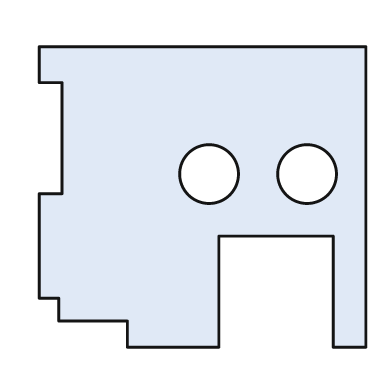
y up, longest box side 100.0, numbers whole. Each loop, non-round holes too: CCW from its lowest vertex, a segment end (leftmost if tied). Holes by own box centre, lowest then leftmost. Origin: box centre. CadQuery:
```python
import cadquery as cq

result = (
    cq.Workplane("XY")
    .moveTo(-23.0, -46.0)
    .lineTo(5.0, -46.0)
    .lineTo(5.0, -12.0)
    .lineTo(40.0, -12.0)
    .lineTo(40.0, -46.0)
    .lineTo(50.0, -46.0)
    .lineTo(50.0, 46.0)
    .lineTo(-50.0, 46.0)
    .lineTo(-50.0, 35.0)
    .lineTo(-43.0, 35.0)
    .lineTo(-43.0, 1.0)
    .lineTo(-50.0, 1.0)
    .lineTo(-50.0, -31.0)
    .lineTo(-44.0, -31.0)
    .lineTo(-44.0, -38.0)
    .lineTo(-23.0, -38.0)
    .close()
    .moveTo(2.0, 7.0)
    .circle(9.0)
    .moveTo(32.0, 7.0)
    .circle(9.0)
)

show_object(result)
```